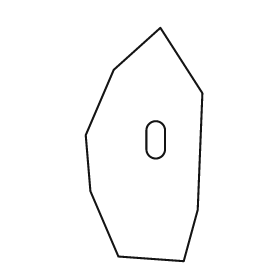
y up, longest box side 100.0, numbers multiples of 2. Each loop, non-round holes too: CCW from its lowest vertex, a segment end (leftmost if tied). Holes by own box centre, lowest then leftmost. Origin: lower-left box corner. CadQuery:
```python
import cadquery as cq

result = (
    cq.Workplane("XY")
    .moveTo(42.0, 0.0)
    .lineTo(48.0, 22.0)
    .lineTo(50.0, 72.0)
    .lineTo(32.0, 100.0)
    .lineTo(12.0, 82.0)
    .lineTo(0.0, 54.0)
    .lineTo(2.0, 30.0)
    .lineTo(14.0, 2.0)
    .close()
    .moveTo(26.0, 48.0)
    .threePointArc((30.0, 44.0), (34.0, 48.0))
    .lineTo(34.0, 56.0)
    .threePointArc((30.0, 60.0), (26.0, 56.0))
    .close()
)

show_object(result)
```